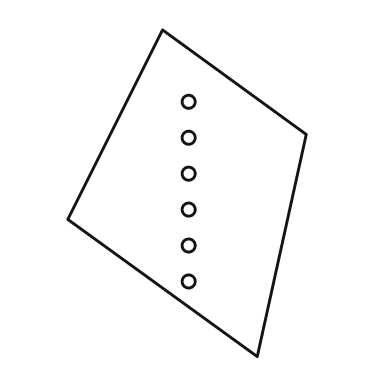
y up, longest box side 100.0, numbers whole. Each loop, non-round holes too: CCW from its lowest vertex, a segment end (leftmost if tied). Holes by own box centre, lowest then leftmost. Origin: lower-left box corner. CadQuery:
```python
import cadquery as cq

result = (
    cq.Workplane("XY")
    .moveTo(58.0, 0.0)
    .lineTo(73.0, 68.0)
    .lineTo(29.0, 100.0)
    .lineTo(0.0, 42.0)
    .close()
    .moveTo(37.0, 23.0)
    .circle(2.0)
    .moveTo(37.0, 34.0)
    .circle(2.0)
    .moveTo(37.0, 45.0)
    .circle(2.0)
    .moveTo(37.0, 56.0)
    .circle(2.0)
    .moveTo(37.0, 67.0)
    .circle(2.0)
    .moveTo(37.0, 78.0)
    .circle(2.0)
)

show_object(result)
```